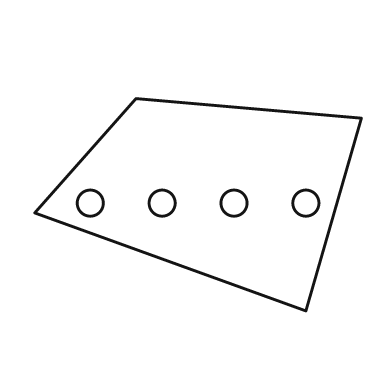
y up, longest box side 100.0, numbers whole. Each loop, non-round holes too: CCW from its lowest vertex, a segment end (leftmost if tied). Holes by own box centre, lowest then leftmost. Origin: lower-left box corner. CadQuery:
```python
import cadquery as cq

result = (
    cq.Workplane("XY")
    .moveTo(83.0, 0.0)
    .lineTo(100.0, 59.0)
    .lineTo(31.0, 65.0)
    .lineTo(0.0, 30.0)
    .close()
    .moveTo(17.0, 33.0)
    .circle(4.0)
    .moveTo(39.0, 33.0)
    .circle(4.0)
    .moveTo(61.0, 33.0)
    .circle(4.0)
    .moveTo(83.0, 33.0)
    .circle(4.0)
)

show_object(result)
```